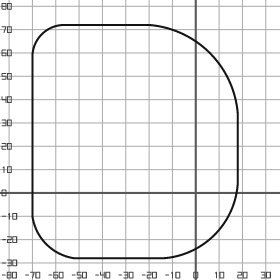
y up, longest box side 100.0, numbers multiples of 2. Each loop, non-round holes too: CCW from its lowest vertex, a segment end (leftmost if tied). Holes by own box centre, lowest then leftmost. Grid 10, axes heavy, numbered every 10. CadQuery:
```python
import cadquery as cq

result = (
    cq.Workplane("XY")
    .moveTo(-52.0, -28.0)
    .lineTo(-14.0, -28.0)
    .threePointArc((8.0, -18.0), (18.0, 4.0))
    .lineTo(18.0, 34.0)
    .threePointArc((6.0, 60.0), (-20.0, 72.0))
    .lineTo(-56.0, 72.0)
    .threePointArc((-66.0, 68.0), (-70.0, 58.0))
    .lineTo(-70.0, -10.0)
    .threePointArc((-64.0, -22.0), (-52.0, -28.0))
    .close()
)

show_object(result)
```